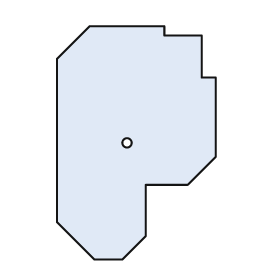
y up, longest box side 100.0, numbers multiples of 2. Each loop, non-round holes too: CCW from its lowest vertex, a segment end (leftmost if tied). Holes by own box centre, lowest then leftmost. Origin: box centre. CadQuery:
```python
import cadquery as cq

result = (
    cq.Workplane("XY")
    .moveTo(-18.0, -50.0)
    .lineTo(-6.0, -50.0)
    .lineTo(4.0, -40.0)
    .lineTo(4.0, -18.0)
    .lineTo(22.0, -18.0)
    .lineTo(34.0, -6.0)
    .lineTo(34.0, 28.0)
    .lineTo(28.0, 28.0)
    .lineTo(28.0, 46.0)
    .lineTo(12.0, 46.0)
    .lineTo(12.0, 50.0)
    .lineTo(-20.0, 50.0)
    .lineTo(-34.0, 36.0)
    .lineTo(-34.0, -34.0)
    .close()
    .moveTo(-4.0, 0.0)
    .circle(2.0)
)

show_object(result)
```